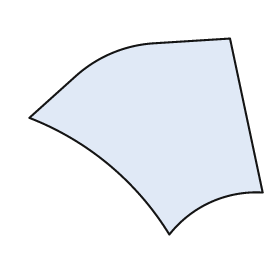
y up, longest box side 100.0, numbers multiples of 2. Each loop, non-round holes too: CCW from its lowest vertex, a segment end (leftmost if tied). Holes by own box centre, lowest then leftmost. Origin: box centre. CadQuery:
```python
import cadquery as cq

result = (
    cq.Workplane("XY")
    .moveTo(10.0, -42.0)
    .threePointArc((28.0, -28.0), (50.0, -24.0))
    .lineTo(36.0, 42.0)
    .lineTo(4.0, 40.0)
    .threePointArc((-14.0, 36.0), (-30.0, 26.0))
    .lineTo(-50.0, 8.0)
    .threePointArc((-16.0, -12.0), (10.0, -42.0))
    .close()
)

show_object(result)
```